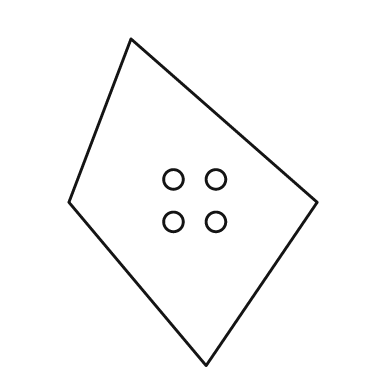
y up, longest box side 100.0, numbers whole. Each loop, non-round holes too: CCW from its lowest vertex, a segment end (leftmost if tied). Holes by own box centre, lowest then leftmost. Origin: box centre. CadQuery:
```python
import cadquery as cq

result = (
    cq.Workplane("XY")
    .moveTo(4.0, -50.0)
    .lineTo(38.0, 0.0)
    .lineTo(-19.0, 50.0)
    .lineTo(-38.0, 0.0)
    .close()
    .moveTo(-6.0, -6.0)
    .circle(3.0)
    .moveTo(7.0, -6.0)
    .circle(3.0)
    .moveTo(-6.0, 7.0)
    .circle(3.0)
    .moveTo(7.0, 7.0)
    .circle(3.0)
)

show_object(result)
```